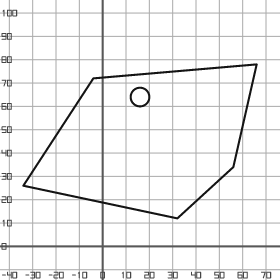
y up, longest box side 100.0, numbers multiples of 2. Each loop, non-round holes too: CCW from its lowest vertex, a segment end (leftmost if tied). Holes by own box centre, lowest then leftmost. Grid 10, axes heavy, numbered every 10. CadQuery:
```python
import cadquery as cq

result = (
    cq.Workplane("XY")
    .moveTo(32.0, 12.0)
    .lineTo(56.0, 34.0)
    .lineTo(66.0, 78.0)
    .lineTo(-4.0, 72.0)
    .lineTo(-34.0, 26.0)
    .close()
    .moveTo(16.0, 64.0)
    .circle(4.0)
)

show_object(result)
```